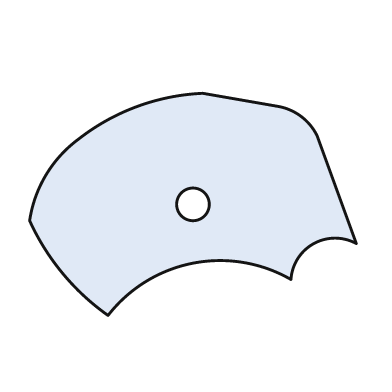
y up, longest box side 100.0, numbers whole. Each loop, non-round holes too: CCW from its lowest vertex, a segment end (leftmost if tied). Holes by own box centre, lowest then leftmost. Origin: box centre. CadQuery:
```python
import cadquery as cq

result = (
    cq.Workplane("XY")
    .moveTo(-26.0, -34.0)
    .threePointArc((0.0, -18.0), (30.0, -23.0))
    .threePointArc((37.0, -12.0), (50.0, -12.0))
    .lineTo(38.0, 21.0)
    .threePointArc((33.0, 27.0), (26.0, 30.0))
    .lineTo(3.0, 34.0)
    .threePointArc((-17.0, 30.0), (-35.0, 20.0))
    .threePointArc((-45.0, 9.0), (-50.0, -5.0))
    .threePointArc((-40.0, -21.0), (-26.0, -34.0))
    .close()
    .moveTo(0.0, 0.0)
    .circle(5.0)
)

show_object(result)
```